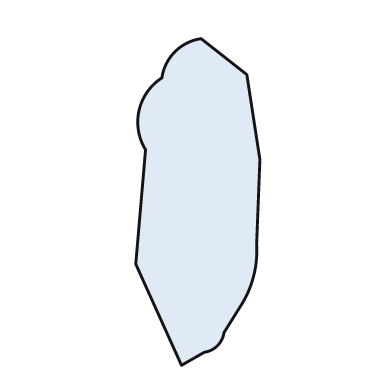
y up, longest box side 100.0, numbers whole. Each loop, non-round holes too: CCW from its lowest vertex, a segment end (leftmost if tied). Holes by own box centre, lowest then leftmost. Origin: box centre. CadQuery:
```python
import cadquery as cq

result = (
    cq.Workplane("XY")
    .moveTo(-5.0, -50.0)
    .lineTo(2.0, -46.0)
    .threePointArc((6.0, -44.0), (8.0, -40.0))
    .lineTo(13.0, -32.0)
    .threePointArc((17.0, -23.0), (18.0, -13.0))
    .lineTo(19.0, 13.0)
    .lineTo(15.0, 39.0)
    .lineTo(1.0, 50.0)
    .threePointArc((-7.0, 46.0), (-11.0, 38.0))
    .threePointArc((-18.0, 28.0), (-16.0, 16.0))
    .lineTo(-19.0, -19.0)
    .close()
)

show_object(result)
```